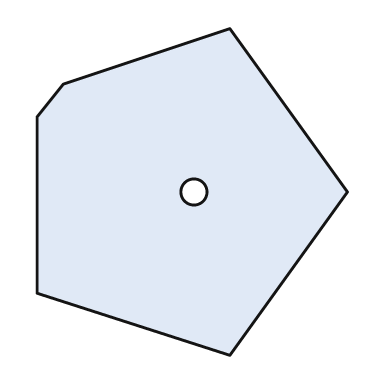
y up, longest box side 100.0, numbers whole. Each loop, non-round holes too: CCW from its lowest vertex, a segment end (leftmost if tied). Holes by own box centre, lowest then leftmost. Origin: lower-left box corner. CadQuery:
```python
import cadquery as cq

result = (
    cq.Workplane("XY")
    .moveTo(59.0, 0.0)
    .lineTo(95.0, 50.0)
    .lineTo(59.0, 100.0)
    .lineTo(8.0, 83.0)
    .lineTo(0.0, 73.0)
    .lineTo(0.0, 19.0)
    .close()
    .moveTo(48.0, 50.0)
    .circle(4.0)
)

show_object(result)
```